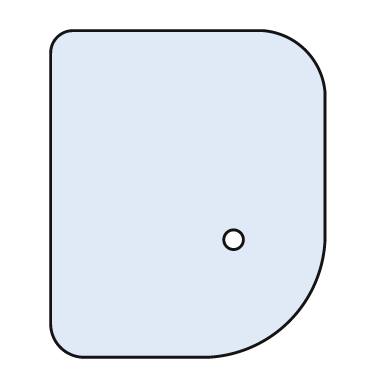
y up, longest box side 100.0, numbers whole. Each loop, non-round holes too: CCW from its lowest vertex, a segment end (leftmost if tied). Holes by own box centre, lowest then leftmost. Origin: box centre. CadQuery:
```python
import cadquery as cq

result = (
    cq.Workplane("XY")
    .moveTo(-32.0, -50.0)
    .lineTo(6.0, -50.0)
    .threePointArc((31.0, -39.0), (42.0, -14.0))
    .lineTo(42.0, 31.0)
    .threePointArc((36.0, 44.0), (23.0, 50.0))
    .lineTo(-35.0, 50.0)
    .threePointArc((-40.0, 48.0), (-42.0, 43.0))
    .lineTo(-42.0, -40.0)
    .threePointArc((-39.0, -47.0), (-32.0, -50.0))
    .close()
    .moveTo(14.0, -14.0)
    .circle(3.0)
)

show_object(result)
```